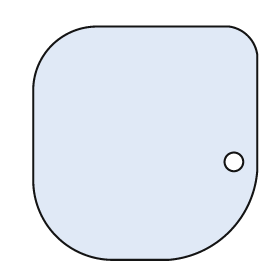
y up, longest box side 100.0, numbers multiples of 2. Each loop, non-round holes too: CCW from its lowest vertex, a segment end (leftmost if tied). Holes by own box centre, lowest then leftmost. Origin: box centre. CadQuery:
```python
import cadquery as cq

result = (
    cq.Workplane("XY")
    .moveTo(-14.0, -50.0)
    .lineTo(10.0, -50.0)
    .threePointArc((36.0, -38.0), (48.0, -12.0))
    .lineTo(48.0, 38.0)
    .threePointArc((44.0, 46.0), (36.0, 50.0))
    .lineTo(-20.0, 50.0)
    .threePointArc((-40.0, 42.0), (-48.0, 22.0))
    .lineTo(-48.0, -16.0)
    .threePointArc((-38.0, -40.0), (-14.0, -50.0))
    .close()
    .moveTo(38.0, -8.0)
    .circle(4.0)
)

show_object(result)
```